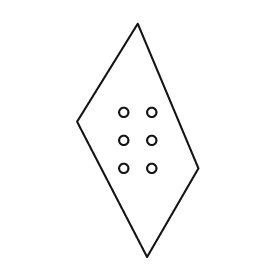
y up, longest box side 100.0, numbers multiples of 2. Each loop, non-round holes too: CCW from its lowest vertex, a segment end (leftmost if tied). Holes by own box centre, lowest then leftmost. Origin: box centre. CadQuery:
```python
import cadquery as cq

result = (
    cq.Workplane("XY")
    .moveTo(4.0, -50.0)
    .lineTo(26.0, -12.0)
    .lineTo(0.0, 50.0)
    .lineTo(-26.0, 8.0)
    .close()
    .moveTo(-6.0, -12.0)
    .circle(2.0)
    .moveTo(6.0, -12.0)
    .circle(2.0)
    .moveTo(-6.0, 0.0)
    .circle(2.0)
    .moveTo(6.0, 0.0)
    .circle(2.0)
    .moveTo(-6.0, 12.0)
    .circle(2.0)
    .moveTo(6.0, 12.0)
    .circle(2.0)
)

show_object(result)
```